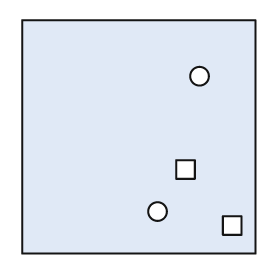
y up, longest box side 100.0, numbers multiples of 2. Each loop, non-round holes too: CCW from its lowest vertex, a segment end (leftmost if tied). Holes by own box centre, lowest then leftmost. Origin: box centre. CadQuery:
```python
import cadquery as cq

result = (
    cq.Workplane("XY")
    .moveTo(-50.0, -50.0)
    .lineTo(50.0, -50.0)
    .lineTo(50.0, 50.0)
    .lineTo(-50.0, 50.0)
    .close()
    .moveTo(36.0, -42.0)
    .lineTo(44.0, -42.0)
    .lineTo(44.0, -34.0)
    .lineTo(36.0, -34.0)
    .close()
    .moveTo(8.0, -32.0)
    .circle(4.0)
    .moveTo(16.0, -18.0)
    .lineTo(24.0, -18.0)
    .lineTo(24.0, -10.0)
    .lineTo(16.0, -10.0)
    .close()
    .moveTo(26.0, 26.0)
    .circle(4.0)
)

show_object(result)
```